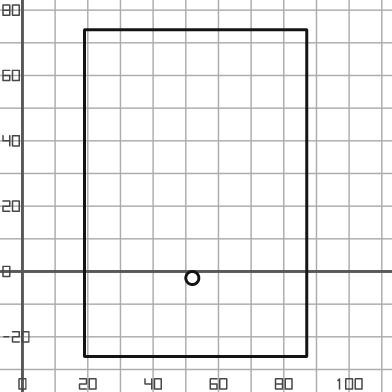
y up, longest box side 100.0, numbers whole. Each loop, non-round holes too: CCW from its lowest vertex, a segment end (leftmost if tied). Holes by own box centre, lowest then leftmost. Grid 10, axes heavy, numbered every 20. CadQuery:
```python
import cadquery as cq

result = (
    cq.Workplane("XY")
    .moveTo(19.0, -26.0)
    .lineTo(87.0, -26.0)
    .lineTo(87.0, 74.0)
    .lineTo(19.0, 74.0)
    .close()
    .moveTo(52.0, -2.0)
    .circle(2.0)
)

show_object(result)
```